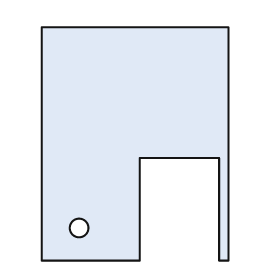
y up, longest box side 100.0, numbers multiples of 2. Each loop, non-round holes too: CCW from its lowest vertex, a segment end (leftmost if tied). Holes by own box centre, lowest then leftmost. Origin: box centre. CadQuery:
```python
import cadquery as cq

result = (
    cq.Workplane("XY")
    .moveTo(-40.0, -50.0)
    .lineTo(2.0, -50.0)
    .lineTo(2.0, -6.0)
    .lineTo(36.0, -6.0)
    .lineTo(36.0, -50.0)
    .lineTo(40.0, -50.0)
    .lineTo(40.0, 50.0)
    .lineTo(-40.0, 50.0)
    .close()
    .moveTo(-24.0, -36.0)
    .circle(4.0)
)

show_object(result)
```